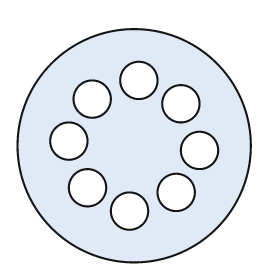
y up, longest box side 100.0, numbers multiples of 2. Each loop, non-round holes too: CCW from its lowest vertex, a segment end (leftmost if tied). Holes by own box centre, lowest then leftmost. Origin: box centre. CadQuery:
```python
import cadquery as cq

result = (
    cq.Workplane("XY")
    .moveTo(0.0, 0.0)
    .circle(50.0)
    .moveTo(-2.0, -28.0)
    .circle(8.0)
    .moveTo(18.0, -20.0)
    .circle(8.0)
    .moveTo(-20.0, -18.0)
    .circle(8.0)
    .moveTo(28.0, -2.0)
    .circle(8.0)
    .moveTo(-28.0, 2.0)
    .circle(8.0)
    .moveTo(20.0, 18.0)
    .circle(8.0)
    .moveTo(-18.0, 20.0)
    .circle(8.0)
    .moveTo(2.0, 28.0)
    .circle(8.0)
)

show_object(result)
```